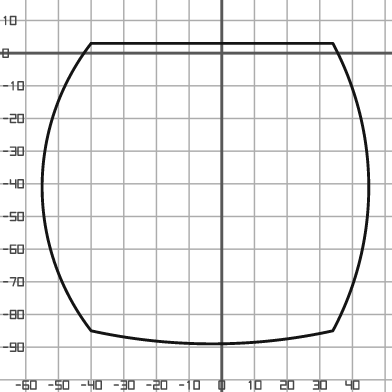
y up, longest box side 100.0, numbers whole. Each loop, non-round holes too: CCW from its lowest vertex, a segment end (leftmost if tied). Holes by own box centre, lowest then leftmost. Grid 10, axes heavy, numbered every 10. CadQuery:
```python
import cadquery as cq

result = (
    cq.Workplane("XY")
    .moveTo(-40.0, -85.0)
    .threePointArc((-3.0, -89.0), (34.0, -85.0))
    .threePointArc((45.0, -41.0), (34.0, 3.0))
    .lineTo(-40.0, 3.0)
    .threePointArc((-55.0, -41.0), (-40.0, -85.0))
    .close()
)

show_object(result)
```